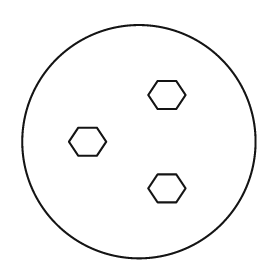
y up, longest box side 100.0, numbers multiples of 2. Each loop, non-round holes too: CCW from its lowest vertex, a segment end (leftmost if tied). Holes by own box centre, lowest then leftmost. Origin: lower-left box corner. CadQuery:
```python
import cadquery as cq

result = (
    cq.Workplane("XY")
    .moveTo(50.0, 50.0)
    .circle(50.0)
    .moveTo(58.0, 24.0)
    .lineTo(66.0, 24.0)
    .lineTo(70.0, 30.0)
    .lineTo(66.0, 36.0)
    .lineTo(58.0, 36.0)
    .lineTo(54.0, 30.0)
    .close()
    .moveTo(24.0, 44.0)
    .lineTo(32.0, 44.0)
    .lineTo(36.0, 50.0)
    .lineTo(32.0, 56.0)
    .lineTo(24.0, 56.0)
    .lineTo(20.0, 50.0)
    .close()
    .moveTo(58.0, 64.0)
    .lineTo(66.0, 64.0)
    .lineTo(70.0, 70.0)
    .lineTo(66.0, 76.0)
    .lineTo(58.0, 76.0)
    .lineTo(54.0, 70.0)
    .close()
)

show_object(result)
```